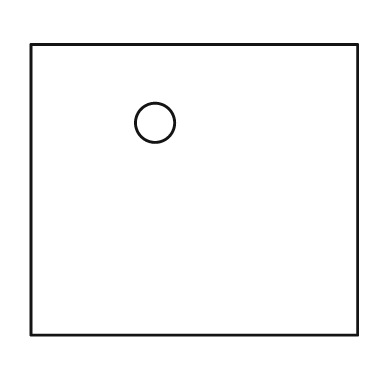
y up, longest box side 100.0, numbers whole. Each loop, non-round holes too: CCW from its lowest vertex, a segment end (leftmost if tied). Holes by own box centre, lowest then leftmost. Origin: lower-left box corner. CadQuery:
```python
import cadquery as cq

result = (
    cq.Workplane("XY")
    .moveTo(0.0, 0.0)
    .lineTo(100.0, 0.0)
    .lineTo(100.0, 89.0)
    .lineTo(0.0, 89.0)
    .close()
    .moveTo(38.0, 65.0)
    .circle(6.0)
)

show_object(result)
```